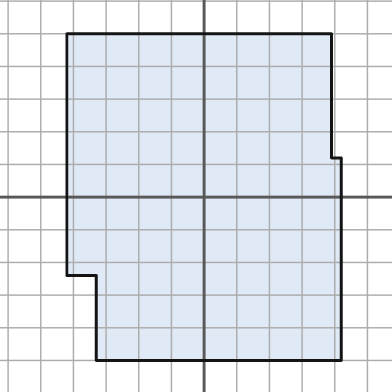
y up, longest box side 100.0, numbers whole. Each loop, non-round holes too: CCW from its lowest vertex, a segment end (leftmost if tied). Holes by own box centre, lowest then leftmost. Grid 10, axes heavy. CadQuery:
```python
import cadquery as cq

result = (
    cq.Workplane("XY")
    .moveTo(-33.0, -50.0)
    .lineTo(42.0, -50.0)
    .lineTo(42.0, 12.0)
    .lineTo(39.0, 12.0)
    .lineTo(39.0, 50.0)
    .lineTo(-42.0, 50.0)
    .lineTo(-42.0, -24.0)
    .lineTo(-33.0, -24.0)
    .close()
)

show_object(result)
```